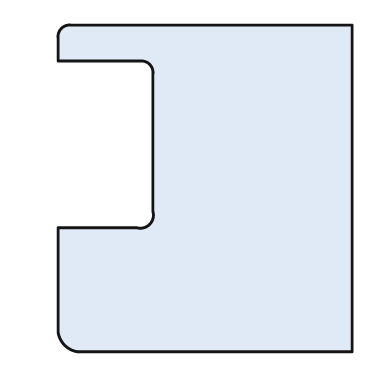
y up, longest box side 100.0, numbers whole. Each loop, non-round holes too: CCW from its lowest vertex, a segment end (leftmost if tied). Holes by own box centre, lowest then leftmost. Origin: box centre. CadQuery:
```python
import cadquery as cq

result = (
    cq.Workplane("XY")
    .moveTo(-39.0, -50.0)
    .lineTo(45.0, -50.0)
    .lineTo(45.0, 50.0)
    .lineTo(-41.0, 50.0)
    .threePointArc((-44.0, 49.0), (-45.0, 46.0))
    .lineTo(-45.0, 39.0)
    .lineTo(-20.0, 39.0)
    .threePointArc((-17.0, 38.0), (-16.0, 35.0))
    .lineTo(-16.0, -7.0)
    .threePointArc((-17.0, -11.0), (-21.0, -12.0))
    .lineTo(-45.0, -12.0)
    .lineTo(-45.0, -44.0)
    .threePointArc((-43.0, -48.0), (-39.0, -50.0))
    .close()
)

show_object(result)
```